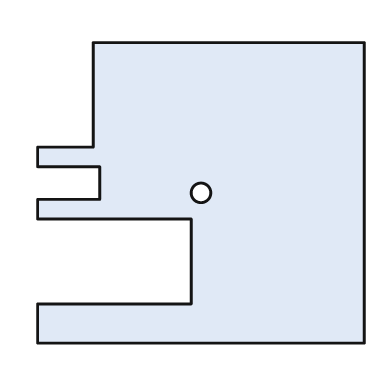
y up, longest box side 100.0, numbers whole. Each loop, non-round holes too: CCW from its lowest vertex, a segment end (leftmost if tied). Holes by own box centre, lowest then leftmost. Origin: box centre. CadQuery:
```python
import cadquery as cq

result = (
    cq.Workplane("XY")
    .moveTo(-50.0, -46.0)
    .lineTo(50.0, -46.0)
    .lineTo(50.0, 46.0)
    .lineTo(-33.0, 46.0)
    .lineTo(-33.0, 14.0)
    .lineTo(-50.0, 14.0)
    .lineTo(-50.0, 8.0)
    .lineTo(-31.0, 8.0)
    .lineTo(-31.0, -2.0)
    .lineTo(-50.0, -2.0)
    .lineTo(-50.0, -8.0)
    .lineTo(-3.0, -8.0)
    .lineTo(-3.0, -34.0)
    .lineTo(-50.0, -34.0)
    .close()
    .moveTo(0.0, 0.0)
    .circle(3.0)
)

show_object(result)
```